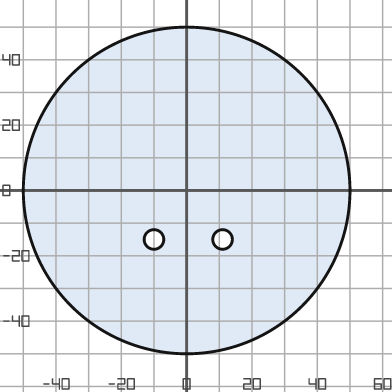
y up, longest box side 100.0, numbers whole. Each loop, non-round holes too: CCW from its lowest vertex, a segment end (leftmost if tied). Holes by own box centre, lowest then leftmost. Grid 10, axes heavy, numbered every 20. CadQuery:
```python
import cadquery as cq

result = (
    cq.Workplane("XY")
    .moveTo(0.0, 0.0)
    .circle(50.0)
    .moveTo(-10.0, -15.0)
    .circle(3.0)
    .moveTo(11.0, -15.0)
    .circle(3.0)
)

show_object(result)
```